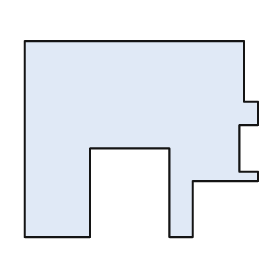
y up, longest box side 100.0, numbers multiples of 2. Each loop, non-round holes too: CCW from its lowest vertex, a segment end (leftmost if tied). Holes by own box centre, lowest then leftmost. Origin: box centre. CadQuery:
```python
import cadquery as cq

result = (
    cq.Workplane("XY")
    .moveTo(-50.0, -42.0)
    .lineTo(-22.0, -42.0)
    .lineTo(-22.0, -4.0)
    .lineTo(12.0, -4.0)
    .lineTo(12.0, -42.0)
    .lineTo(22.0, -42.0)
    .lineTo(22.0, -18.0)
    .lineTo(50.0, -18.0)
    .lineTo(50.0, -14.0)
    .lineTo(42.0, -14.0)
    .lineTo(42.0, 6.0)
    .lineTo(50.0, 6.0)
    .lineTo(50.0, 16.0)
    .lineTo(44.0, 16.0)
    .lineTo(44.0, 42.0)
    .lineTo(-50.0, 42.0)
    .close()
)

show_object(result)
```